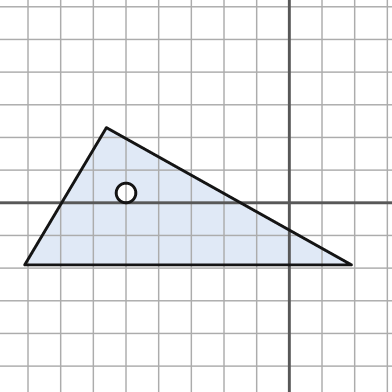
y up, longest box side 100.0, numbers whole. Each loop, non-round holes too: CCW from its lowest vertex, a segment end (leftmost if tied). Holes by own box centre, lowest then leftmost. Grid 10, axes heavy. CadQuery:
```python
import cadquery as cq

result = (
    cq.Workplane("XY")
    .moveTo(-81.0, -19.0)
    .lineTo(19.0, -19.0)
    .lineTo(-56.0, 23.0)
    .close()
    .moveTo(-50.0, 3.0)
    .circle(3.0)
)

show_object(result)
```